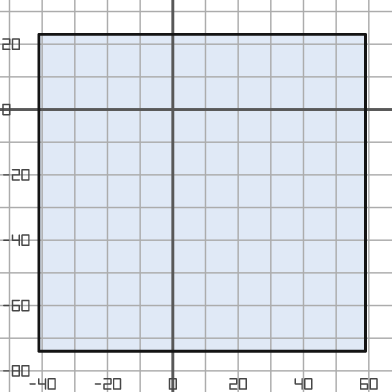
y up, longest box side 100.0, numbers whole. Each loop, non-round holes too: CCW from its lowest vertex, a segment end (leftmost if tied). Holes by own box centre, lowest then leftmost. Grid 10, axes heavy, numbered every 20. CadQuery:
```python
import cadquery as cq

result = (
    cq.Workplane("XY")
    .moveTo(-41.0, -74.0)
    .lineTo(59.0, -74.0)
    .lineTo(59.0, 23.0)
    .lineTo(-41.0, 23.0)
    .close()
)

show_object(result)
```